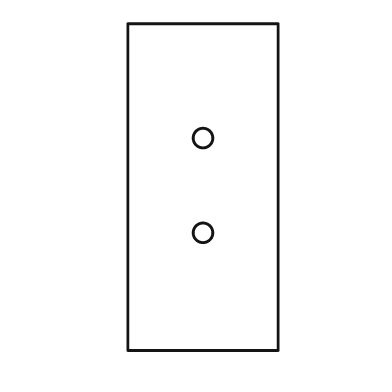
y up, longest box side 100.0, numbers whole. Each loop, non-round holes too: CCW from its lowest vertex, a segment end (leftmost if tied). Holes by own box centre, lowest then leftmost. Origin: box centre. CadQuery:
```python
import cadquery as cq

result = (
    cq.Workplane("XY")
    .moveTo(-23.0, -50.0)
    .lineTo(23.0, -50.0)
    .lineTo(23.0, 50.0)
    .lineTo(-23.0, 50.0)
    .close()
    .moveTo(0.0, -14.0)
    .circle(3.0)
    .moveTo(0.0, 15.0)
    .circle(3.0)
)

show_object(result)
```